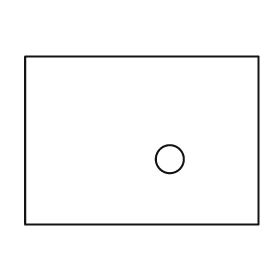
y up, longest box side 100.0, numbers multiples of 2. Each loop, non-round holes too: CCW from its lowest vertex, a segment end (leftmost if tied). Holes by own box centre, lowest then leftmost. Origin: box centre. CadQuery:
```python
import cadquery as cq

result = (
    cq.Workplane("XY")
    .moveTo(-50.0, -36.0)
    .lineTo(50.0, -36.0)
    .lineTo(50.0, 36.0)
    .lineTo(-50.0, 36.0)
    .close()
    .moveTo(12.0, -8.0)
    .circle(6.0)
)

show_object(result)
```